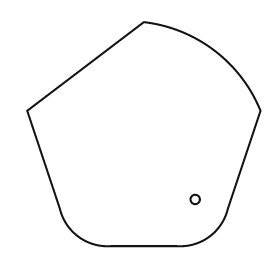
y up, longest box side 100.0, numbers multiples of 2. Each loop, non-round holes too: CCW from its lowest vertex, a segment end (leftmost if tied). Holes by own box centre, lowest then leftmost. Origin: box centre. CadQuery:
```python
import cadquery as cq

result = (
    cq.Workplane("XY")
    .moveTo(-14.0, -48.0)
    .lineTo(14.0, -48.0)
    .threePointArc((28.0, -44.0), (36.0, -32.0))
    .lineTo(50.0, 10.0)
    .threePointArc((30.0, 36.0), (0.0, 48.0))
    .lineTo(-50.0, 10.0)
    .lineTo(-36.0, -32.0)
    .threePointArc((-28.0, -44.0), (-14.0, -48.0))
    .close()
    .moveTo(22.0, -28.0)
    .circle(2.0)
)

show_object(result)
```